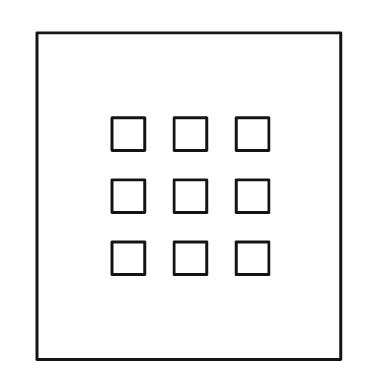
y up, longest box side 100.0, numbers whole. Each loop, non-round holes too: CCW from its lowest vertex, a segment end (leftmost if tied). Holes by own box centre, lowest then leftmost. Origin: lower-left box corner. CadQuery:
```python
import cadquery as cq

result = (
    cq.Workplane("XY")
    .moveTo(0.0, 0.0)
    .lineTo(93.0, 0.0)
    .lineTo(93.0, 100.0)
    .lineTo(0.0, 100.0)
    .close()
    .moveTo(23.0, 26.0)
    .lineTo(33.0, 26.0)
    .lineTo(33.0, 36.0)
    .lineTo(23.0, 36.0)
    .close()
    .moveTo(42.0, 26.0)
    .lineTo(52.0, 26.0)
    .lineTo(52.0, 36.0)
    .lineTo(42.0, 36.0)
    .close()
    .moveTo(61.0, 26.0)
    .lineTo(71.0, 26.0)
    .lineTo(71.0, 36.0)
    .lineTo(61.0, 36.0)
    .close()
    .moveTo(23.0, 45.0)
    .lineTo(33.0, 45.0)
    .lineTo(33.0, 55.0)
    .lineTo(23.0, 55.0)
    .close()
    .moveTo(42.0, 45.0)
    .lineTo(52.0, 45.0)
    .lineTo(52.0, 55.0)
    .lineTo(42.0, 55.0)
    .close()
    .moveTo(61.0, 45.0)
    .lineTo(71.0, 45.0)
    .lineTo(71.0, 55.0)
    .lineTo(61.0, 55.0)
    .close()
    .moveTo(23.0, 64.0)
    .lineTo(33.0, 64.0)
    .lineTo(33.0, 74.0)
    .lineTo(23.0, 74.0)
    .close()
    .moveTo(42.0, 64.0)
    .lineTo(52.0, 64.0)
    .lineTo(52.0, 74.0)
    .lineTo(42.0, 74.0)
    .close()
    .moveTo(61.0, 64.0)
    .lineTo(71.0, 64.0)
    .lineTo(71.0, 74.0)
    .lineTo(61.0, 74.0)
    .close()
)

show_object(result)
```